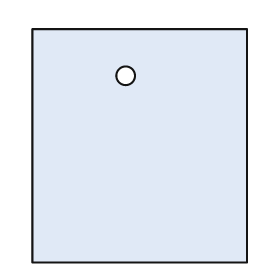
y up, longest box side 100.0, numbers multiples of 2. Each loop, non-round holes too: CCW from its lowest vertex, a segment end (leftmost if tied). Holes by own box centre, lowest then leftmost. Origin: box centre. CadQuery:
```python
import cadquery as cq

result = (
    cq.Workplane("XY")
    .moveTo(-46.0, -50.0)
    .lineTo(46.0, -50.0)
    .lineTo(46.0, 50.0)
    .lineTo(-46.0, 50.0)
    .close()
    .moveTo(-6.0, 30.0)
    .circle(4.0)
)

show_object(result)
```